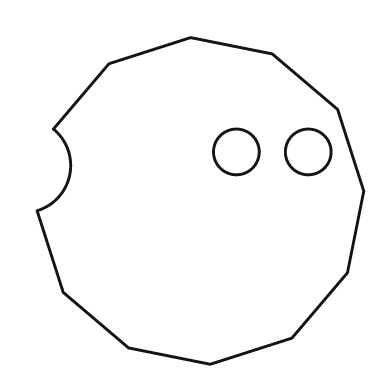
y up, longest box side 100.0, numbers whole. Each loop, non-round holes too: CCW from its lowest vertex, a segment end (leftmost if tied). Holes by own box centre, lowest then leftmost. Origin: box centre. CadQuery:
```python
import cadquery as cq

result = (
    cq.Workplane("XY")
    .moveTo(3.0, -50.0)
    .lineTo(28.0, -42.0)
    .lineTo(45.0, -22.0)
    .lineTo(50.0, 3.0)
    .lineTo(42.0, 28.0)
    .lineTo(22.0, 45.0)
    .lineTo(-3.0, 50.0)
    .lineTo(-28.0, 42.0)
    .lineTo(-45.0, 22.0)
    .threePointArc((-40.0, 8.0), (-50.0, -3.0))
    .lineTo(-42.0, -28.0)
    .lineTo(-22.0, -45.0)
    .close()
    .moveTo(11.0, 15.0)
    .circle(7.0)
    .moveTo(33.0, 15.0)
    .circle(7.0)
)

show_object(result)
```